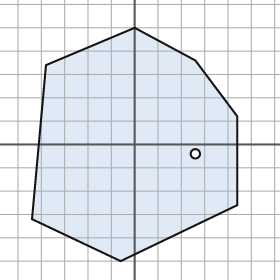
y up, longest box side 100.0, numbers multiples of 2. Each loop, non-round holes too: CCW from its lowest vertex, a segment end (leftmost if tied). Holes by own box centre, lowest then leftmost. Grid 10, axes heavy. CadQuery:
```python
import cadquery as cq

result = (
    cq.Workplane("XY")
    .moveTo(-6.0, -50.0)
    .lineTo(44.0, -26.0)
    .lineTo(44.0, 12.0)
    .lineTo(26.0, 36.0)
    .lineTo(0.0, 50.0)
    .lineTo(-38.0, 34.0)
    .lineTo(-44.0, -32.0)
    .close()
    .moveTo(26.0, -4.0)
    .circle(2.0)
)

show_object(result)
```